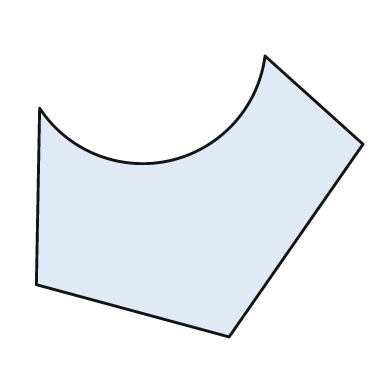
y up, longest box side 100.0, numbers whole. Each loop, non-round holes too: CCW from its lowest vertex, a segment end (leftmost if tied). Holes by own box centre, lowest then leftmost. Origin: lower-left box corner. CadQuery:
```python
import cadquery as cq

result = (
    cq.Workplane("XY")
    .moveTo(59.0, 0.0)
    .lineTo(100.0, 59.0)
    .lineTo(70.0, 86.0)
    .threePointArc((41.0, 54.0), (1.0, 70.0))
    .lineTo(0.0, 16.0)
    .close()
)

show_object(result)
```